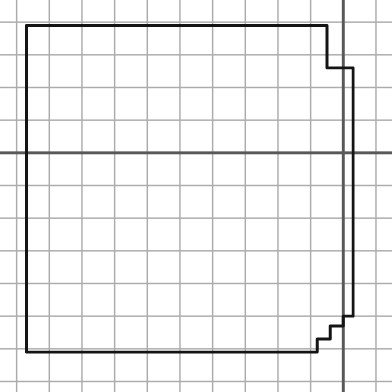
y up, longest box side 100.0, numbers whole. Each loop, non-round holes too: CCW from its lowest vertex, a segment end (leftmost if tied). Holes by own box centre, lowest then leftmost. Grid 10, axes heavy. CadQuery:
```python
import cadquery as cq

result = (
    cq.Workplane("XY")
    .moveTo(-97.0, -61.0)
    .lineTo(-8.0, -61.0)
    .lineTo(-8.0, -57.0)
    .lineTo(-4.0, -57.0)
    .lineTo(-4.0, -53.0)
    .lineTo(0.0, -53.0)
    .lineTo(0.0, -50.0)
    .lineTo(3.0, -50.0)
    .lineTo(3.0, 26.0)
    .lineTo(-5.0, 26.0)
    .lineTo(-5.0, 39.0)
    .lineTo(-97.0, 39.0)
    .close()
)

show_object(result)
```